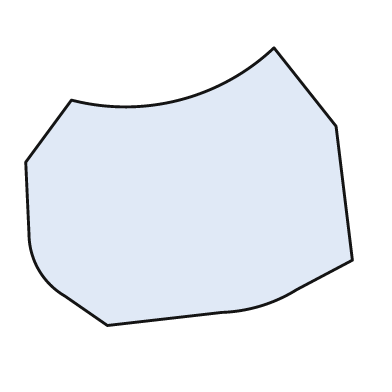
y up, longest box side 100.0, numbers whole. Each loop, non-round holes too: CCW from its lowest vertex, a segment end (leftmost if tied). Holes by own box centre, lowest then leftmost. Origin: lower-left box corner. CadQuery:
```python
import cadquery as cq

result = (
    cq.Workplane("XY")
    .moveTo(25.0, 0.0)
    .lineTo(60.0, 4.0)
    .threePointArc((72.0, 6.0), (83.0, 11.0))
    .lineTo(100.0, 20.0)
    .lineTo(95.0, 61.0)
    .lineTo(76.0, 85.0)
    .threePointArc((47.0, 69.0), (14.0, 69.0))
    .lineTo(0.0, 50.0)
    .lineTo(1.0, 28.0)
    .threePointArc((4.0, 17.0), (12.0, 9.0))
    .close()
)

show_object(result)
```